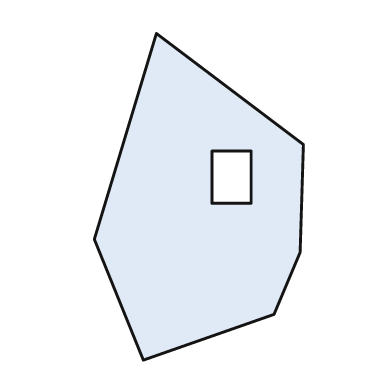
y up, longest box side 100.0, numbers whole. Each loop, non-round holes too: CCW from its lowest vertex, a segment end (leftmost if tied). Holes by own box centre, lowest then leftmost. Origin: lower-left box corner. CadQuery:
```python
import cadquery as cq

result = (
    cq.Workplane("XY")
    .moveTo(15.0, 0.0)
    .lineTo(55.0, 14.0)
    .lineTo(63.0, 33.0)
    .lineTo(64.0, 66.0)
    .lineTo(19.0, 100.0)
    .lineTo(0.0, 37.0)
    .close()
    .moveTo(36.0, 48.0)
    .lineTo(48.0, 48.0)
    .lineTo(48.0, 64.0)
    .lineTo(36.0, 64.0)
    .close()
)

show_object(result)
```